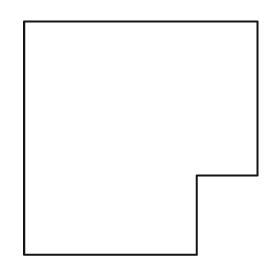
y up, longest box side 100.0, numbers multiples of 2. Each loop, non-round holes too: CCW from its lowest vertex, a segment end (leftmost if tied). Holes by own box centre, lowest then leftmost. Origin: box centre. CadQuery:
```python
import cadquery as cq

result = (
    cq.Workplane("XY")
    .moveTo(-50.0, -50.0)
    .lineTo(24.0, -50.0)
    .lineTo(24.0, -16.0)
    .lineTo(50.0, -16.0)
    .lineTo(50.0, 50.0)
    .lineTo(-50.0, 50.0)
    .close()
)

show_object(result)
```